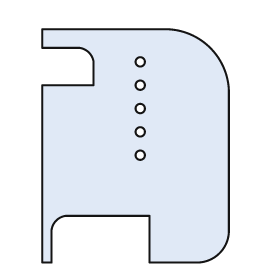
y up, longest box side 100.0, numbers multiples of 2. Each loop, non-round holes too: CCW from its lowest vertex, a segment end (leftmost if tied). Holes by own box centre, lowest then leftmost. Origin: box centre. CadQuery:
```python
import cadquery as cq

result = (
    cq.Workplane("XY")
    .moveTo(-40.0, -50.0)
    .lineTo(-36.0, -50.0)
    .lineTo(-36.0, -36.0)
    .threePointArc((-34.0, -32.0), (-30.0, -30.0))
    .lineTo(6.0, -30.0)
    .lineTo(6.0, -50.0)
    .lineTo(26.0, -50.0)
    .threePointArc((36.0, -46.0), (40.0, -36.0))
    .lineTo(40.0, 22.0)
    .threePointArc((32.0, 42.0), (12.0, 50.0))
    .lineTo(-40.0, 50.0)
    .lineTo(-40.0, 42.0)
    .lineTo(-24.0, 42.0)
    .threePointArc((-20.0, 40.0), (-18.0, 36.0))
    .lineTo(-18.0, 26.0)
    .lineTo(-40.0, 26.0)
    .close()
    .moveTo(2.0, -4.0)
    .circle(2.0)
    .moveTo(2.0, 6.0)
    .circle(2.0)
    .moveTo(2.0, 16.0)
    .circle(2.0)
    .moveTo(2.0, 26.0)
    .circle(2.0)
    .moveTo(2.0, 36.0)
    .circle(2.0)
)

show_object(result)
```